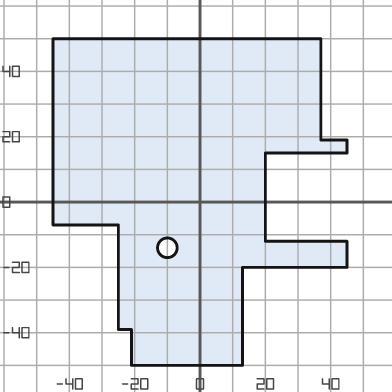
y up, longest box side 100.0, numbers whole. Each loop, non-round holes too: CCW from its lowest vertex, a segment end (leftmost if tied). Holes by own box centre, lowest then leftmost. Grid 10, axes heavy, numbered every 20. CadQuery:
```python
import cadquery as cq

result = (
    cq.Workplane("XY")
    .moveTo(-21.0, -50.0)
    .lineTo(13.0, -50.0)
    .lineTo(13.0, -20.0)
    .lineTo(45.0, -20.0)
    .lineTo(45.0, -12.0)
    .lineTo(20.0, -12.0)
    .lineTo(20.0, 15.0)
    .lineTo(45.0, 15.0)
    .lineTo(45.0, 19.0)
    .lineTo(37.0, 19.0)
    .lineTo(37.0, 50.0)
    .lineTo(-45.0, 50.0)
    .lineTo(-45.0, -7.0)
    .lineTo(-25.0, -7.0)
    .lineTo(-25.0, -39.0)
    .lineTo(-21.0, -39.0)
    .close()
    .moveTo(-10.0, -14.0)
    .circle(3.0)
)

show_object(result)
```